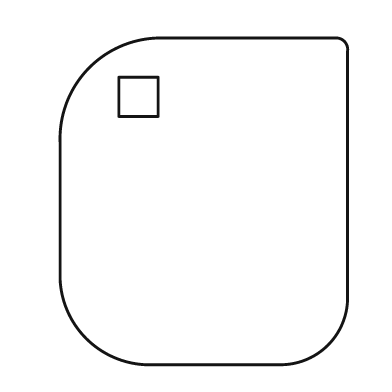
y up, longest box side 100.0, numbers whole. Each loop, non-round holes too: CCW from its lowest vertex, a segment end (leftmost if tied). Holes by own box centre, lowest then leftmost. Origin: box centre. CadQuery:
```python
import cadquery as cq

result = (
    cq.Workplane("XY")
    .moveTo(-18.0, -50.0)
    .lineTo(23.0, -50.0)
    .threePointArc((38.0, -44.0), (44.0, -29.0))
    .lineTo(44.0, 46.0)
    .threePointArc((43.0, 49.0), (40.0, 50.0))
    .lineTo(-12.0, 50.0)
    .threePointArc((-35.0, 41.0), (-44.0, 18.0))
    .lineTo(-44.0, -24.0)
    .threePointArc((-36.0, -42.0), (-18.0, -50.0))
    .close()
    .moveTo(-26.0, 26.0)
    .lineTo(-14.0, 26.0)
    .lineTo(-14.0, 38.0)
    .lineTo(-26.0, 38.0)
    .close()
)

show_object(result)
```